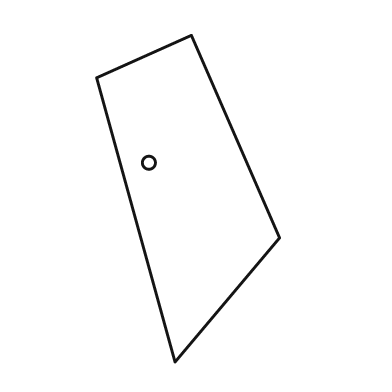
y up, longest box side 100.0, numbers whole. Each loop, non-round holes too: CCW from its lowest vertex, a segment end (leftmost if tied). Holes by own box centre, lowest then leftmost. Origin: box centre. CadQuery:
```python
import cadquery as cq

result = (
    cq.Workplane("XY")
    .moveTo(-4.0, -50.0)
    .lineTo(28.0, -12.0)
    .lineTo(1.0, 50.0)
    .lineTo(-28.0, 37.0)
    .close()
    .moveTo(-12.0, 11.0)
    .circle(2.0)
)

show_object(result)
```